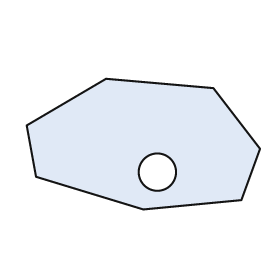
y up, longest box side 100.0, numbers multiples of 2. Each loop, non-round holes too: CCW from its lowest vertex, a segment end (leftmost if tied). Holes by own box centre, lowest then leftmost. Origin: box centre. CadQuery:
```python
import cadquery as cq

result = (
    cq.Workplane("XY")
    .moveTo(0.0, -28.0)
    .lineTo(42.0, -24.0)
    .lineTo(50.0, -2.0)
    .lineTo(30.0, 24.0)
    .lineTo(-16.0, 28.0)
    .lineTo(-50.0, 8.0)
    .lineTo(-46.0, -14.0)
    .close()
    .moveTo(6.0, -12.0)
    .circle(8.0)
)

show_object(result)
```